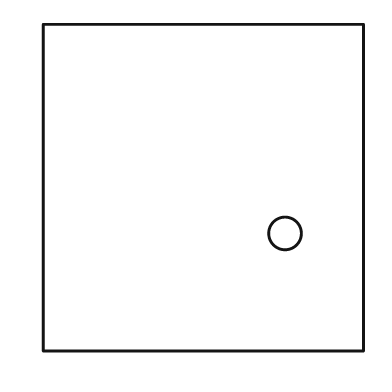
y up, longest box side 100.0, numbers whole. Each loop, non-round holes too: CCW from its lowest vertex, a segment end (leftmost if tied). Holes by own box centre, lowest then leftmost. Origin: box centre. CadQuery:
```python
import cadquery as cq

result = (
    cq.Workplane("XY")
    .moveTo(-49.0, -50.0)
    .lineTo(49.0, -50.0)
    .lineTo(49.0, 50.0)
    .lineTo(-49.0, 50.0)
    .close()
    .moveTo(25.0, -14.0)
    .circle(5.0)
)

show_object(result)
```